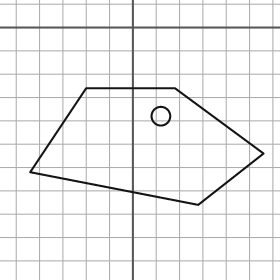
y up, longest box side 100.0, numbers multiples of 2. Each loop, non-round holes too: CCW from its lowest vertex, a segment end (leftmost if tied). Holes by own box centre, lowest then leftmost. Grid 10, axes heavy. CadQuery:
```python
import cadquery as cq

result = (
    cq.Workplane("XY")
    .moveTo(28.0, -76.0)
    .lineTo(56.0, -54.0)
    .lineTo(18.0, -26.0)
    .lineTo(-20.0, -26.0)
    .lineTo(-44.0, -62.0)
    .close()
    .moveTo(12.0, -38.0)
    .circle(4.0)
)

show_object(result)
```